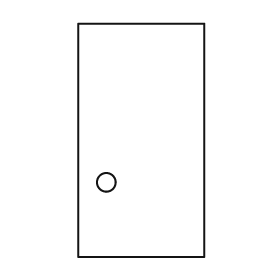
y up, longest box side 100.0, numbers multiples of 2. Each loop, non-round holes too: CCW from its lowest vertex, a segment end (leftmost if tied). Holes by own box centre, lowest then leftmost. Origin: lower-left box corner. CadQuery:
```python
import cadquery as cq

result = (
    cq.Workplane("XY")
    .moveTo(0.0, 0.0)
    .lineTo(54.0, 0.0)
    .lineTo(54.0, 100.0)
    .lineTo(0.0, 100.0)
    .close()
    .moveTo(12.0, 32.0)
    .circle(4.0)
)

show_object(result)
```